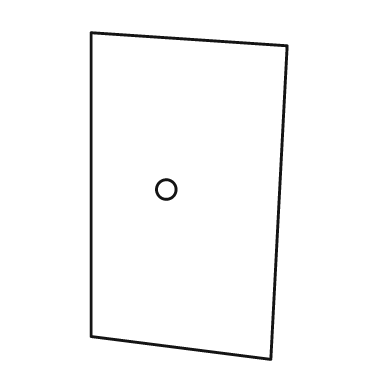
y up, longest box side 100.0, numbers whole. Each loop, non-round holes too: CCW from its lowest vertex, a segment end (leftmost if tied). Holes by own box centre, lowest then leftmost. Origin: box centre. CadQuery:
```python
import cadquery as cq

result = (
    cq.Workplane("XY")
    .moveTo(25.0, -50.0)
    .lineTo(30.0, 46.0)
    .lineTo(-30.0, 50.0)
    .lineTo(-30.0, -43.0)
    .close()
    .moveTo(-7.0, 2.0)
    .circle(3.0)
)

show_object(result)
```